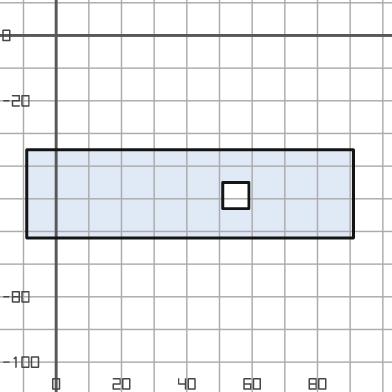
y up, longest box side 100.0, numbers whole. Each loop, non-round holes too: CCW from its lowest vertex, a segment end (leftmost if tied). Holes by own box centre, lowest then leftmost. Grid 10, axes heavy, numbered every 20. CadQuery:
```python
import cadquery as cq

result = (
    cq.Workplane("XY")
    .moveTo(-9.0, -62.0)
    .lineTo(91.0, -62.0)
    .lineTo(91.0, -35.0)
    .lineTo(-9.0, -35.0)
    .close()
    .moveTo(51.0, -53.0)
    .lineTo(59.0, -53.0)
    .lineTo(59.0, -45.0)
    .lineTo(51.0, -45.0)
    .close()
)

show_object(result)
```